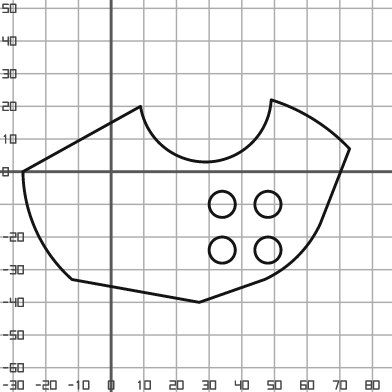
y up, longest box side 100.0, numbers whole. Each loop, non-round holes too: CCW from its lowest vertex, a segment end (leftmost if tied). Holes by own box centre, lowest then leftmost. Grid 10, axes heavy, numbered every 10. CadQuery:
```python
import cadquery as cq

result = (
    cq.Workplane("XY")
    .moveTo(27.0, -40.0)
    .lineTo(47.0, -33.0)
    .threePointArc((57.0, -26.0), (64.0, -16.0))
    .lineTo(73.0, 7.0)
    .threePointArc((62.0, 16.0), (49.0, 22.0))
    .threePointArc((30.0, 3.0), (9.0, 20.0))
    .lineTo(-27.0, 0.0)
    .threePointArc((-23.0, -18.0), (-12.0, -33.0))
    .close()
    .moveTo(34.0, -24.0)
    .circle(4.0)
    .moveTo(48.0, -24.0)
    .circle(4.0)
    .moveTo(34.0, -10.0)
    .circle(4.0)
    .moveTo(48.0, -10.0)
    .circle(4.0)
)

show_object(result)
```